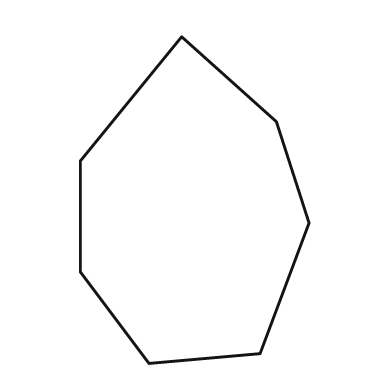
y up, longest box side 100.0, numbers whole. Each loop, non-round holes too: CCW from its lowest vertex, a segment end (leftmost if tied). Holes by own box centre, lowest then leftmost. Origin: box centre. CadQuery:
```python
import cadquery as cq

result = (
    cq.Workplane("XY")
    .moveTo(-14.0, -50.0)
    .lineTo(20.0, -47.0)
    .lineTo(35.0, -7.0)
    .lineTo(25.0, 24.0)
    .lineTo(-4.0, 50.0)
    .lineTo(-35.0, 12.0)
    .lineTo(-35.0, -22.0)
    .close()
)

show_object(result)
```